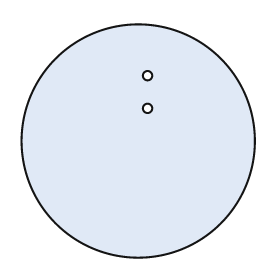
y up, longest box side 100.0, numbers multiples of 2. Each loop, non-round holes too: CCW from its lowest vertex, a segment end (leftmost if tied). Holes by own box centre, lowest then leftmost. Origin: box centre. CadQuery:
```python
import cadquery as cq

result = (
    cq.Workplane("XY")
    .moveTo(0.0, 0.0)
    .circle(50.0)
    .moveTo(4.0, 14.0)
    .circle(2.0)
    .moveTo(4.0, 28.0)
    .circle(2.0)
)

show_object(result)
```